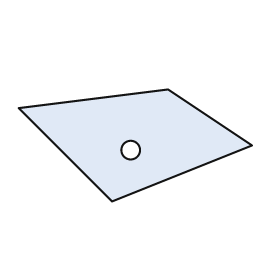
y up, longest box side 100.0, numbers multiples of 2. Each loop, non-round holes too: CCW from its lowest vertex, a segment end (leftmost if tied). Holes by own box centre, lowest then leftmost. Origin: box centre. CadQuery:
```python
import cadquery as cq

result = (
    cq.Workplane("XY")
    .moveTo(-10.0, -24.0)
    .lineTo(50.0, 0.0)
    .lineTo(14.0, 24.0)
    .lineTo(-50.0, 16.0)
    .close()
    .moveTo(-2.0, -2.0)
    .circle(4.0)
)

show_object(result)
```